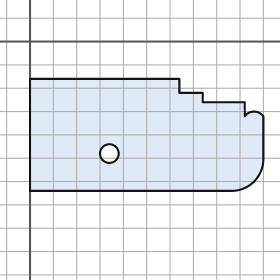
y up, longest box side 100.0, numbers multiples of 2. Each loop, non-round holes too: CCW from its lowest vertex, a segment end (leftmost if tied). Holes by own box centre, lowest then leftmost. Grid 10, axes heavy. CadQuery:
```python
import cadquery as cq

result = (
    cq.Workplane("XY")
    .moveTo(0.0, -64.0)
    .lineTo(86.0, -64.0)
    .threePointArc((96.0, -60.0), (100.0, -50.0))
    .lineTo(100.0, -32.0)
    .threePointArc((96.0, -30.0), (92.0, -32.0))
    .lineTo(92.0, -26.0)
    .lineTo(74.0, -26.0)
    .lineTo(74.0, -22.0)
    .lineTo(64.0, -22.0)
    .lineTo(64.0, -16.0)
    .lineTo(0.0, -16.0)
    .close()
    .moveTo(34.0, -48.0)
    .circle(4.0)
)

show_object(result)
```